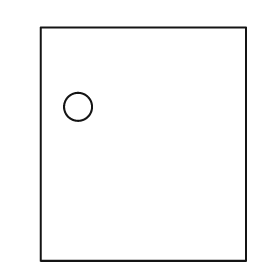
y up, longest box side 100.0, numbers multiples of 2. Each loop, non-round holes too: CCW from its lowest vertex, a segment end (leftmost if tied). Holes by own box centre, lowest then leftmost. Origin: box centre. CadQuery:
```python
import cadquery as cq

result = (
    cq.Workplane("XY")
    .moveTo(-44.0, -50.0)
    .lineTo(44.0, -50.0)
    .lineTo(44.0, 50.0)
    .lineTo(-44.0, 50.0)
    .close()
    .moveTo(-28.0, 16.0)
    .circle(6.0)
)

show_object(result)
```